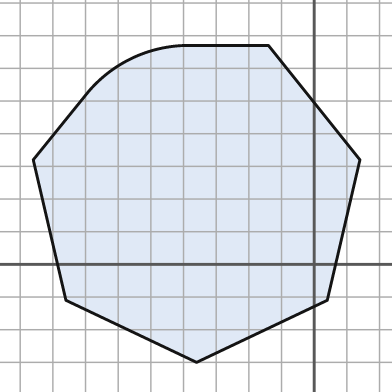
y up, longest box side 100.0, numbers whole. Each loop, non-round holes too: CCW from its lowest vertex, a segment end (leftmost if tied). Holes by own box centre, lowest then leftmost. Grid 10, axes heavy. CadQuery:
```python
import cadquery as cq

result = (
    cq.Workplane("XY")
    .moveTo(-36.0, -30.0)
    .lineTo(4.0, -11.0)
    .lineTo(14.0, 32.0)
    .lineTo(-14.0, 67.0)
    .lineTo(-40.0, 67.0)
    .threePointArc((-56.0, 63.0), (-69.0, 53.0))
    .lineTo(-86.0, 32.0)
    .lineTo(-76.0, -11.0)
    .close()
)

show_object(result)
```